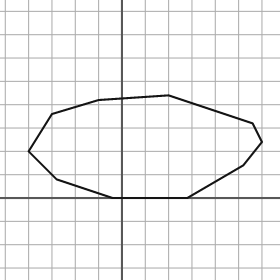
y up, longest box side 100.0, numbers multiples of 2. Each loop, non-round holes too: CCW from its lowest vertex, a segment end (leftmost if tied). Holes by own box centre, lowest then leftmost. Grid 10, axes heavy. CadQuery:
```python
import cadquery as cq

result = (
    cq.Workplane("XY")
    .moveTo(-4.0, 0.0)
    .lineTo(28.0, 0.0)
    .lineTo(52.0, 14.0)
    .lineTo(60.0, 24.0)
    .lineTo(56.0, 32.0)
    .lineTo(20.0, 44.0)
    .lineTo(-10.0, 42.0)
    .lineTo(-30.0, 36.0)
    .lineTo(-40.0, 20.0)
    .lineTo(-28.0, 8.0)
    .close()
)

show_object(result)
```